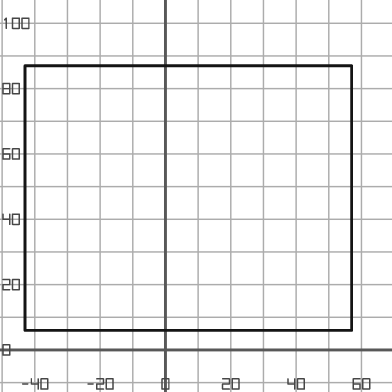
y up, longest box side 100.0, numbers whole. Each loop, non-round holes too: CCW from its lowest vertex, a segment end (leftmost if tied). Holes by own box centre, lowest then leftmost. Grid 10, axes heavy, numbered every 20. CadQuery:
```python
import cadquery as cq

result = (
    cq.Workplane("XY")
    .moveTo(-43.0, 6.0)
    .lineTo(57.0, 6.0)
    .lineTo(57.0, 87.0)
    .lineTo(-43.0, 87.0)
    .close()
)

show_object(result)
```